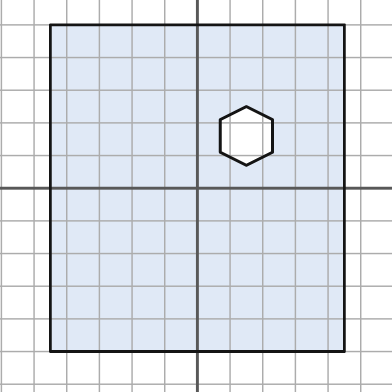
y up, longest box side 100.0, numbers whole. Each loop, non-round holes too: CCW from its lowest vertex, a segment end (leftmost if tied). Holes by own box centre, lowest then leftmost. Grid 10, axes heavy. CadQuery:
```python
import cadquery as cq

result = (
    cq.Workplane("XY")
    .moveTo(-45.0, -50.0)
    .lineTo(45.0, -50.0)
    .lineTo(45.0, 50.0)
    .lineTo(-45.0, 50.0)
    .close()
    .moveTo(15.0, 7.0)
    .lineTo(23.0, 11.0)
    .lineTo(23.0, 21.0)
    .lineTo(15.0, 25.0)
    .lineTo(7.0, 21.0)
    .lineTo(7.0, 11.0)
    .close()
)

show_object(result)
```